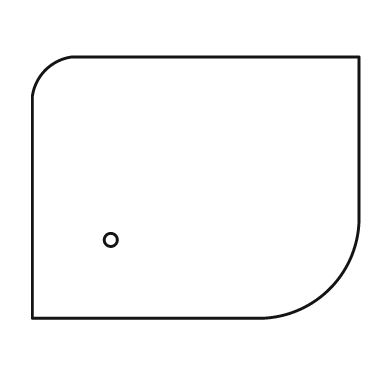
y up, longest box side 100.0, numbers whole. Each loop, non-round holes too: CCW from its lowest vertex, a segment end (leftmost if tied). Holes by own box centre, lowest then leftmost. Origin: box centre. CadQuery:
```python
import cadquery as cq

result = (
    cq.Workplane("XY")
    .moveTo(-50.0, -40.0)
    .lineTo(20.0, -40.0)
    .threePointArc((41.0, -31.0), (50.0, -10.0))
    .lineTo(50.0, 40.0)
    .lineTo(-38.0, 40.0)
    .threePointArc((-46.0, 36.0), (-50.0, 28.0))
    .close()
    .moveTo(-26.0, -16.0)
    .circle(2.0)
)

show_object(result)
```